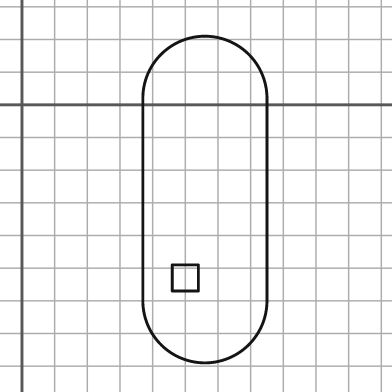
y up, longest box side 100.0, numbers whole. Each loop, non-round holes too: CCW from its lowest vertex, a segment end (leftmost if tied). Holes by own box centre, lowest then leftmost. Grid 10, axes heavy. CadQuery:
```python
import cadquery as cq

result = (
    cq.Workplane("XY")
    .moveTo(37.0, -60.0)
    .threePointArc((56.0, -79.0), (75.0, -60.0))
    .lineTo(75.0, 2.0)
    .threePointArc((56.0, 21.0), (37.0, 2.0))
    .close()
    .moveTo(46.0, -57.0)
    .lineTo(54.0, -57.0)
    .lineTo(54.0, -49.0)
    .lineTo(46.0, -49.0)
    .close()
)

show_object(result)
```